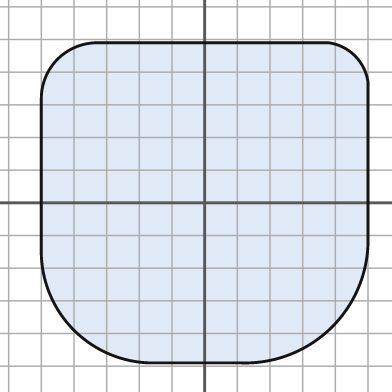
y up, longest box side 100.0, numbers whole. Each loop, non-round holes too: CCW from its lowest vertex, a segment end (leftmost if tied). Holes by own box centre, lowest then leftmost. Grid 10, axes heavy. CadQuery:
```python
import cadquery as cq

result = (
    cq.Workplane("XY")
    .moveTo(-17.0, -49.0)
    .lineTo(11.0, -49.0)
    .threePointArc((39.0, -38.0), (50.0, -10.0))
    .lineTo(50.0, 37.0)
    .threePointArc((46.0, 45.0), (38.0, 49.0))
    .lineTo(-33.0, 49.0)
    .threePointArc((-45.0, 44.0), (-50.0, 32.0))
    .lineTo(-50.0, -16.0)
    .threePointArc((-40.0, -39.0), (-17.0, -49.0))
    .close()
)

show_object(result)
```